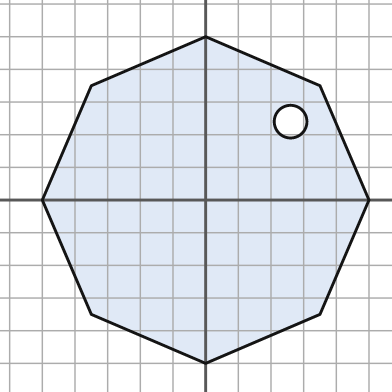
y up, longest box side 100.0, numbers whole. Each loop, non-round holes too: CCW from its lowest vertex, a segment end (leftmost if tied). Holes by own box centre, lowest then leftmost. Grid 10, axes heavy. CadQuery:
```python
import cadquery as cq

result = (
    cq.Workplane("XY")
    .moveTo(0.0, -50.0)
    .lineTo(35.0, -35.0)
    .lineTo(50.0, 0.0)
    .lineTo(35.0, 35.0)
    .lineTo(0.0, 50.0)
    .lineTo(-35.0, 35.0)
    .lineTo(-50.0, 0.0)
    .lineTo(-35.0, -35.0)
    .close()
    .moveTo(26.0, 24.0)
    .circle(5.0)
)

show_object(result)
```